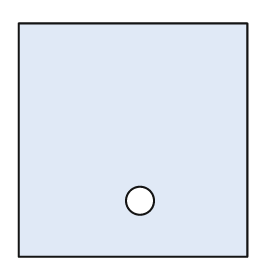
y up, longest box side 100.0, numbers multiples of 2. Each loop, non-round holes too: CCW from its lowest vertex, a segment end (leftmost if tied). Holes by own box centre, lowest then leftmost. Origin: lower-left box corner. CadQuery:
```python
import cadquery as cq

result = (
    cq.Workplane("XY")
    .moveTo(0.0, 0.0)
    .lineTo(98.0, 0.0)
    .lineTo(98.0, 100.0)
    .lineTo(0.0, 100.0)
    .close()
    .moveTo(52.0, 24.0)
    .circle(6.0)
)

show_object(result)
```